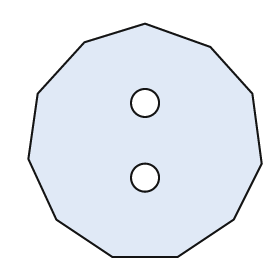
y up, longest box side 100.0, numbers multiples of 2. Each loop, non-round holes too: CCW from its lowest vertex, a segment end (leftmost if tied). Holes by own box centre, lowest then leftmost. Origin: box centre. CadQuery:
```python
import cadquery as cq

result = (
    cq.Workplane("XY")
    .moveTo(-14.0, -50.0)
    .lineTo(14.0, -50.0)
    .lineTo(38.0, -34.0)
    .lineTo(50.0, -10.0)
    .lineTo(46.0, 20.0)
    .lineTo(28.0, 40.0)
    .lineTo(0.0, 50.0)
    .lineTo(-26.0, 42.0)
    .lineTo(-46.0, 20.0)
    .lineTo(-50.0, -8.0)
    .lineTo(-38.0, -34.0)
    .close()
    .moveTo(0.0, -16.0)
    .circle(6.0)
    .moveTo(0.0, 16.0)
    .circle(6.0)
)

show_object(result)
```